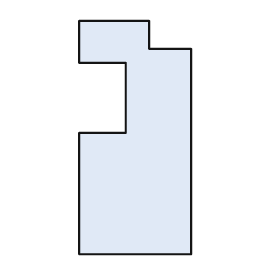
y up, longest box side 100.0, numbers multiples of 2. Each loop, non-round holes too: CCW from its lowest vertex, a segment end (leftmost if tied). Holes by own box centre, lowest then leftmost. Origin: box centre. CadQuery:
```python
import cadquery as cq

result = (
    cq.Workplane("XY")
    .moveTo(-24.0, -50.0)
    .lineTo(24.0, -50.0)
    .lineTo(24.0, 38.0)
    .lineTo(6.0, 38.0)
    .lineTo(6.0, 50.0)
    .lineTo(-24.0, 50.0)
    .lineTo(-24.0, 32.0)
    .lineTo(-4.0, 32.0)
    .lineTo(-4.0, 2.0)
    .lineTo(-24.0, 2.0)
    .close()
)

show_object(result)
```